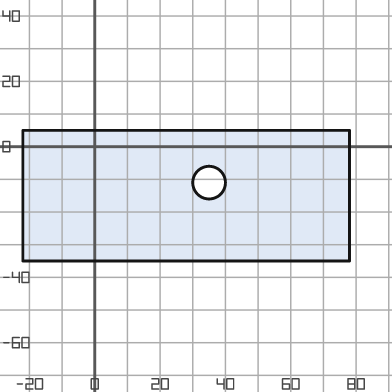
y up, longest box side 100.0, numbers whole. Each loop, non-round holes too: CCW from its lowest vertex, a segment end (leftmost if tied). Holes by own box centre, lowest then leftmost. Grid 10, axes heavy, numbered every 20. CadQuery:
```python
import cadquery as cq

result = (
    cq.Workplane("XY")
    .moveTo(-22.0, -35.0)
    .lineTo(78.0, -35.0)
    .lineTo(78.0, 5.0)
    .lineTo(-22.0, 5.0)
    .close()
    .moveTo(35.0, -11.0)
    .circle(5.0)
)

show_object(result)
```